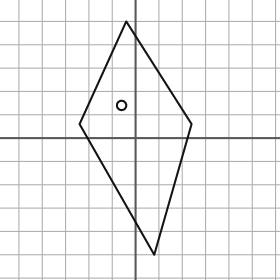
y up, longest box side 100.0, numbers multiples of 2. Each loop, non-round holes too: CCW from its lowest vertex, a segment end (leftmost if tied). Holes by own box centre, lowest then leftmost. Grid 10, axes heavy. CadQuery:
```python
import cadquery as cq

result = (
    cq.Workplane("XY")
    .moveTo(8.0, -50.0)
    .lineTo(24.0, 6.0)
    .lineTo(-4.0, 50.0)
    .lineTo(-24.0, 6.0)
    .close()
    .moveTo(-6.0, 14.0)
    .circle(2.0)
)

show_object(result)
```